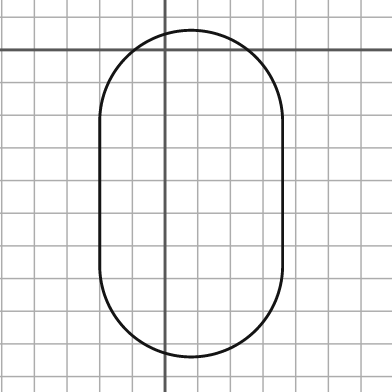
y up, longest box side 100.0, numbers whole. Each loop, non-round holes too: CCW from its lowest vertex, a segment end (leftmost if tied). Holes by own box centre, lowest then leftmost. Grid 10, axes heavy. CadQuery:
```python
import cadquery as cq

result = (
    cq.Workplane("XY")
    .moveTo(-20.0, -66.0)
    .threePointArc((8.0, -94.0), (36.0, -66.0))
    .lineTo(36.0, -22.0)
    .threePointArc((8.0, 6.0), (-20.0, -22.0))
    .close()
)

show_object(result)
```